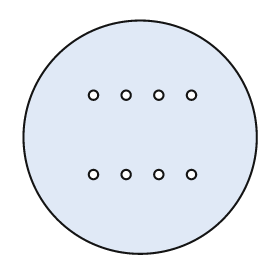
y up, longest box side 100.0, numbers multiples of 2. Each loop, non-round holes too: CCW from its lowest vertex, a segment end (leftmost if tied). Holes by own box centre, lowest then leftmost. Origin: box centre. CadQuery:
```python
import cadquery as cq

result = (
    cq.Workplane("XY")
    .moveTo(0.0, 0.0)
    .circle(50.0)
    .moveTo(-20.0, -16.0)
    .circle(2.0)
    .moveTo(-6.0, -16.0)
    .circle(2.0)
    .moveTo(8.0, -16.0)
    .circle(2.0)
    .moveTo(22.0, -16.0)
    .circle(2.0)
    .moveTo(-20.0, 18.0)
    .circle(2.0)
    .moveTo(-6.0, 18.0)
    .circle(2.0)
    .moveTo(8.0, 18.0)
    .circle(2.0)
    .moveTo(22.0, 18.0)
    .circle(2.0)
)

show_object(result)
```